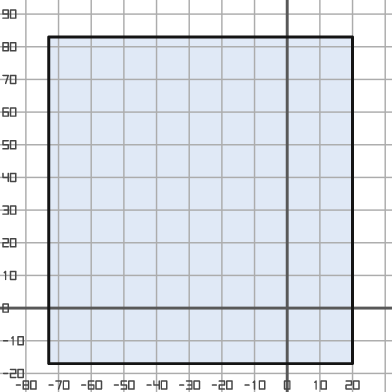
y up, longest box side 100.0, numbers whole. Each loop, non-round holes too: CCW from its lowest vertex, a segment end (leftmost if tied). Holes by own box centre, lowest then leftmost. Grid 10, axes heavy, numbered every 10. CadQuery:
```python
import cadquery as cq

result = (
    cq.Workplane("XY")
    .moveTo(-73.0, -17.0)
    .lineTo(20.0, -17.0)
    .lineTo(20.0, 83.0)
    .lineTo(-73.0, 83.0)
    .close()
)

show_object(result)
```